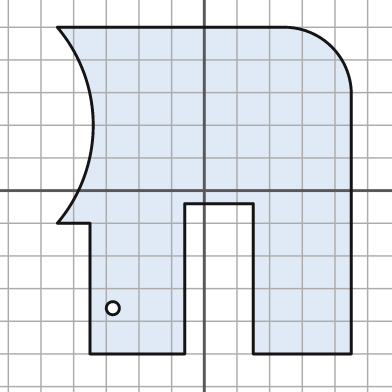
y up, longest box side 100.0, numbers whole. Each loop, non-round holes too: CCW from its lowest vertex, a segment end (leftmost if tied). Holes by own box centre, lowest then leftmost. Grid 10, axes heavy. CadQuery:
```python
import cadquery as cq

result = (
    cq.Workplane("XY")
    .moveTo(-35.0, -50.0)
    .lineTo(-6.0, -50.0)
    .lineTo(-6.0, -4.0)
    .lineTo(15.0, -4.0)
    .lineTo(15.0, -50.0)
    .lineTo(45.0, -50.0)
    .lineTo(45.0, 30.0)
    .threePointArc((39.0, 44.0), (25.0, 50.0))
    .lineTo(-45.0, 50.0)
    .threePointArc((-34.0, 20.0), (-45.0, -10.0))
    .lineTo(-35.0, -10.0)
    .close()
    .moveTo(-28.0, -36.0)
    .circle(2.0)
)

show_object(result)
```